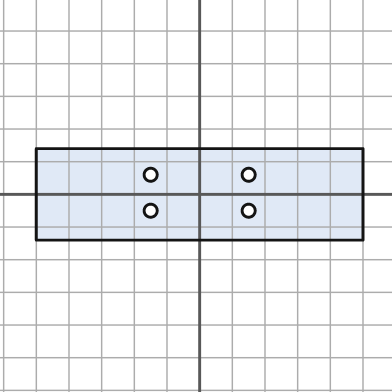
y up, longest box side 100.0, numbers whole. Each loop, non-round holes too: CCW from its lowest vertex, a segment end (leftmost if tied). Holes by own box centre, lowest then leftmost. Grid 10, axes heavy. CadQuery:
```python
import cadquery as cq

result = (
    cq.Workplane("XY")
    .moveTo(-50.0, -14.0)
    .lineTo(50.0, -14.0)
    .lineTo(50.0, 14.0)
    .lineTo(-50.0, 14.0)
    .close()
    .moveTo(-15.0, -5.0)
    .circle(2.0)
    .moveTo(15.0, -5.0)
    .circle(2.0)
    .moveTo(-15.0, 6.0)
    .circle(2.0)
    .moveTo(15.0, 6.0)
    .circle(2.0)
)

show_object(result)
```